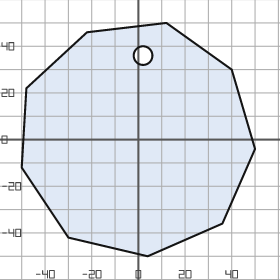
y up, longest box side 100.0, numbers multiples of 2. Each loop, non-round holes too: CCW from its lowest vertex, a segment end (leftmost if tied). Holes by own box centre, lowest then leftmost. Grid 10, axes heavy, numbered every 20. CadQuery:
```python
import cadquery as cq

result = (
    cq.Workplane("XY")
    .moveTo(4.0, -50.0)
    .lineTo(36.0, -36.0)
    .lineTo(50.0, -4.0)
    .lineTo(40.0, 30.0)
    .lineTo(12.0, 50.0)
    .lineTo(-22.0, 46.0)
    .lineTo(-48.0, 22.0)
    .lineTo(-50.0, -12.0)
    .lineTo(-30.0, -42.0)
    .close()
    .moveTo(2.0, 36.0)
    .circle(4.0)
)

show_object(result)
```